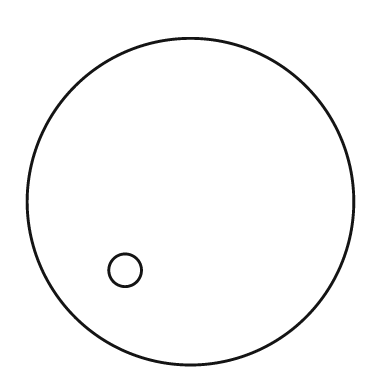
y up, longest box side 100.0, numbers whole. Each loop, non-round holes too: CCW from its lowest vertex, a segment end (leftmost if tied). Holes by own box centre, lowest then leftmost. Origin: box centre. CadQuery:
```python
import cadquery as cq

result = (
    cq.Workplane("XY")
    .moveTo(0.0, 0.0)
    .circle(50.0)
    .moveTo(-20.0, -21.0)
    .circle(5.0)
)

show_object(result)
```